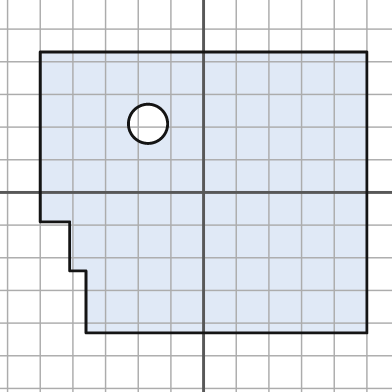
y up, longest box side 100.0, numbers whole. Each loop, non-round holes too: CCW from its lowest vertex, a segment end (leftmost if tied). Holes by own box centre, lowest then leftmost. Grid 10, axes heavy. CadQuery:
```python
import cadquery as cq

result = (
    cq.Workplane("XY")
    .moveTo(-36.0, -43.0)
    .lineTo(50.0, -43.0)
    .lineTo(50.0, 43.0)
    .lineTo(-50.0, 43.0)
    .lineTo(-50.0, -9.0)
    .lineTo(-41.0, -9.0)
    .lineTo(-41.0, -24.0)
    .lineTo(-36.0, -24.0)
    .close()
    .moveTo(-17.0, 21.0)
    .circle(6.0)
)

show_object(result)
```